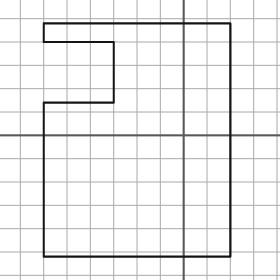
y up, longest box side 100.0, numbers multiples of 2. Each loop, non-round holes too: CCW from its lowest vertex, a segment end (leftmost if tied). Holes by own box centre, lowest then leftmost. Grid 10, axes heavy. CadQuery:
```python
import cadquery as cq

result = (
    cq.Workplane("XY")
    .moveTo(-60.0, -52.0)
    .lineTo(20.0, -52.0)
    .lineTo(20.0, 48.0)
    .lineTo(-60.0, 48.0)
    .lineTo(-60.0, 40.0)
    .lineTo(-30.0, 40.0)
    .lineTo(-30.0, 14.0)
    .lineTo(-60.0, 14.0)
    .close()
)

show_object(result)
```